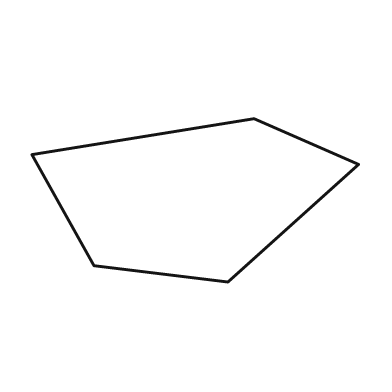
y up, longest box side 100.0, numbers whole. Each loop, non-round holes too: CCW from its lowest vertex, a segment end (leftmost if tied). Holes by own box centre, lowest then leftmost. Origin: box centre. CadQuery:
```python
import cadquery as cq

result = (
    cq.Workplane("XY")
    .moveTo(10.0, -25.0)
    .lineTo(50.0, 11.0)
    .lineTo(18.0, 25.0)
    .lineTo(-50.0, 14.0)
    .lineTo(-31.0, -20.0)
    .close()
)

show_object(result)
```